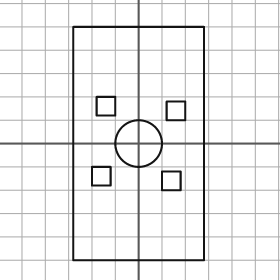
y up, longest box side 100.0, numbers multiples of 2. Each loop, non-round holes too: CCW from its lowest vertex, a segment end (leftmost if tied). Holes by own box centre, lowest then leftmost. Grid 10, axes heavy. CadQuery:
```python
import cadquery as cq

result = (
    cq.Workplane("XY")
    .moveTo(-28.0, -50.0)
    .lineTo(28.0, -50.0)
    .lineTo(28.0, 50.0)
    .lineTo(-28.0, 50.0)
    .close()
    .moveTo(10.0, -20.0)
    .lineTo(18.0, -20.0)
    .lineTo(18.0, -12.0)
    .lineTo(10.0, -12.0)
    .close()
    .moveTo(-20.0, -18.0)
    .lineTo(-12.0, -18.0)
    .lineTo(-12.0, -10.0)
    .lineTo(-20.0, -10.0)
    .close()
    .moveTo(0.0, 0.0)
    .circle(10.0)
    .moveTo(12.0, 10.0)
    .lineTo(20.0, 10.0)
    .lineTo(20.0, 18.0)
    .lineTo(12.0, 18.0)
    .close()
    .moveTo(-18.0, 12.0)
    .lineTo(-10.0, 12.0)
    .lineTo(-10.0, 20.0)
    .lineTo(-18.0, 20.0)
    .close()
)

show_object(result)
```